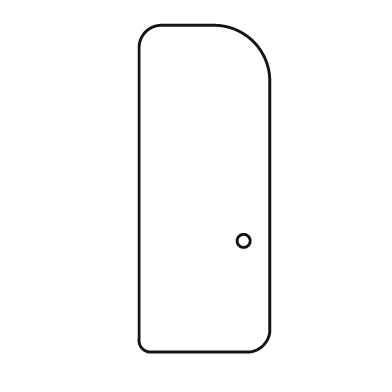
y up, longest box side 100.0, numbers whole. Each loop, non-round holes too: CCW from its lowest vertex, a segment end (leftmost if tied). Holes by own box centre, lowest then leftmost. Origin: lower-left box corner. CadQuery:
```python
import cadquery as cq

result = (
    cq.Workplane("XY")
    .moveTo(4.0, 0.0)
    .lineTo(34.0, 0.0)
    .threePointArc((38.0, 2.0), (40.0, 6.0))
    .lineTo(40.0, 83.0)
    .threePointArc((35.0, 95.0), (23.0, 100.0))
    .lineTo(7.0, 100.0)
    .threePointArc((2.0, 98.0), (0.0, 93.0))
    .lineTo(0.0, 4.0)
    .threePointArc((1.0, 1.0), (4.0, 0.0))
    .close()
    .moveTo(32.0, 34.0)
    .circle(2.0)
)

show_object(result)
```